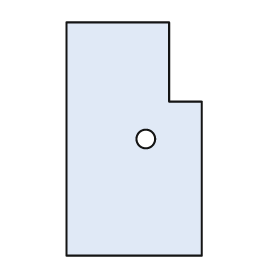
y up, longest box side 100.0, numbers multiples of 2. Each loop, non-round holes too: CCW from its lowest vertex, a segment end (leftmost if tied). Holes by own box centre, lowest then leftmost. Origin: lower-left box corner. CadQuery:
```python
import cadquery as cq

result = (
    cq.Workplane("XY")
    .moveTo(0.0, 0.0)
    .lineTo(58.0, 0.0)
    .lineTo(58.0, 66.0)
    .lineTo(44.0, 66.0)
    .lineTo(44.0, 100.0)
    .lineTo(0.0, 100.0)
    .close()
    .moveTo(34.0, 50.0)
    .circle(4.0)
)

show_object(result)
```